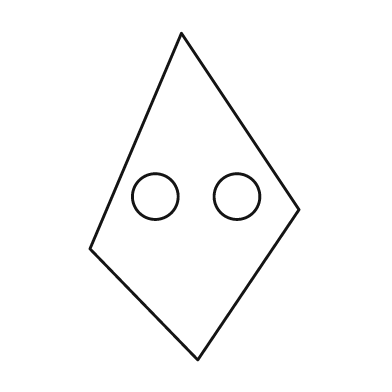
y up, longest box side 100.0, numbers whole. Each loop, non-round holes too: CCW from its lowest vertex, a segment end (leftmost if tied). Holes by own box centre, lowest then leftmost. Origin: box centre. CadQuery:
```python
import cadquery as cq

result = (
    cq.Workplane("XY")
    .moveTo(1.0, -50.0)
    .lineTo(32.0, -4.0)
    .lineTo(-4.0, 50.0)
    .lineTo(-32.0, -16.0)
    .close()
    .moveTo(-12.0, 0.0)
    .circle(7.0)
    .moveTo(13.0, 0.0)
    .circle(7.0)
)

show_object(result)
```